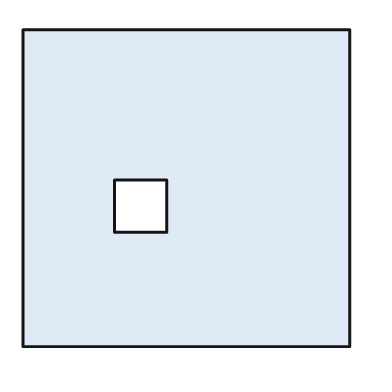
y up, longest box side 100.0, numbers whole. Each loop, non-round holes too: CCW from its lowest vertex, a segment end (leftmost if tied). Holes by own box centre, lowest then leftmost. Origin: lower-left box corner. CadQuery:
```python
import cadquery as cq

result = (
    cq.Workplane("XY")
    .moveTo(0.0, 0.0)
    .lineTo(100.0, 0.0)
    .lineTo(100.0, 97.0)
    .lineTo(0.0, 97.0)
    .close()
    .moveTo(28.0, 35.0)
    .lineTo(44.0, 35.0)
    .lineTo(44.0, 51.0)
    .lineTo(28.0, 51.0)
    .close()
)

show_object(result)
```